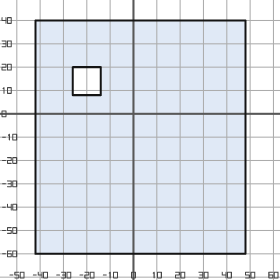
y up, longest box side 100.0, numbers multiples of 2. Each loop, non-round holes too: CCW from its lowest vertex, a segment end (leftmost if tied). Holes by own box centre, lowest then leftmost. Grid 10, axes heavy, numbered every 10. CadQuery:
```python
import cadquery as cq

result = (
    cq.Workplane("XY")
    .moveTo(-42.0, -60.0)
    .lineTo(48.0, -60.0)
    .lineTo(48.0, 40.0)
    .lineTo(-42.0, 40.0)
    .close()
    .moveTo(-26.0, 8.0)
    .lineTo(-14.0, 8.0)
    .lineTo(-14.0, 20.0)
    .lineTo(-26.0, 20.0)
    .close()
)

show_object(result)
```